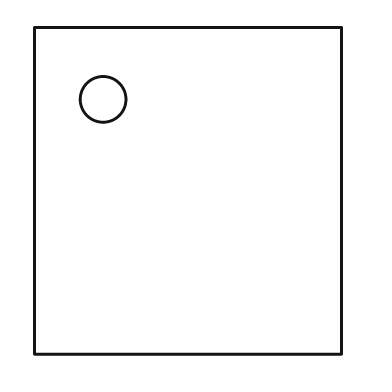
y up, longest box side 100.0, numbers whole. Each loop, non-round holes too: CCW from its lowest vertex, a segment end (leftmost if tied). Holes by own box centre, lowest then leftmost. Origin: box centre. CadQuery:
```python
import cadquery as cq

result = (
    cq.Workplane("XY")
    .moveTo(-47.0, -50.0)
    .lineTo(47.0, -50.0)
    .lineTo(47.0, 50.0)
    .lineTo(-47.0, 50.0)
    .close()
    .moveTo(-26.0, 28.0)
    .circle(7.0)
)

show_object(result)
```